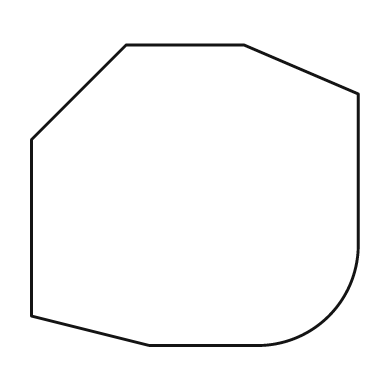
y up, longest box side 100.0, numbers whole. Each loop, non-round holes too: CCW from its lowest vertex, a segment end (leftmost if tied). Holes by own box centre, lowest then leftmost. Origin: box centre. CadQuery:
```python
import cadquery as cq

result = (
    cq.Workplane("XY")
    .moveTo(-14.0, -46.0)
    .lineTo(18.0, -46.0)
    .threePointArc((41.0, -37.0), (50.0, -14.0))
    .lineTo(50.0, 31.0)
    .lineTo(15.0, 46.0)
    .lineTo(-21.0, 46.0)
    .lineTo(-50.0, 17.0)
    .lineTo(-50.0, -37.0)
    .close()
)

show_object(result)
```